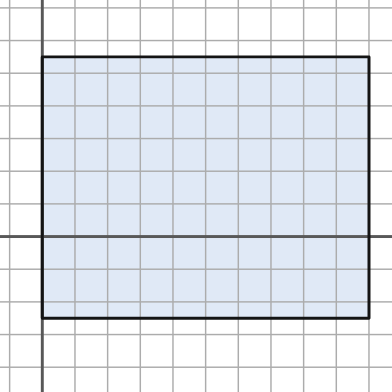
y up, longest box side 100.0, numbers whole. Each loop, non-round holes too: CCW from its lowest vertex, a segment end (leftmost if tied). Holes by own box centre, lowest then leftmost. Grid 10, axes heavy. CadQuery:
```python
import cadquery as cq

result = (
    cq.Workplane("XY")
    .moveTo(0.0, -25.0)
    .lineTo(100.0, -25.0)
    .lineTo(100.0, 55.0)
    .lineTo(0.0, 55.0)
    .close()
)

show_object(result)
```